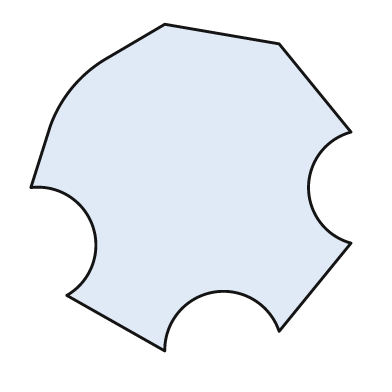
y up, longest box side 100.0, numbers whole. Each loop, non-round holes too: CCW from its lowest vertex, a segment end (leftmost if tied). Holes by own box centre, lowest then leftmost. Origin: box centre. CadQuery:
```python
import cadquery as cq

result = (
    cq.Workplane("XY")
    .moveTo(-8.0, -50.0)
    .threePointArc((7.0, -32.0), (27.0, -44.0))
    .lineTo(49.0, -17.0)
    .threePointArc((36.0, 0.0), (49.0, 17.0))
    .lineTo(27.0, 44.0)
    .lineTo(-8.0, 50.0)
    .lineTo(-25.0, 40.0)
    .threePointArc((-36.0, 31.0), (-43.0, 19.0))
    .lineTo(-49.0, 0.0)
    .threePointArc((-30.0, -12.0), (-38.0, -33.0))
    .close()
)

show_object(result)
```